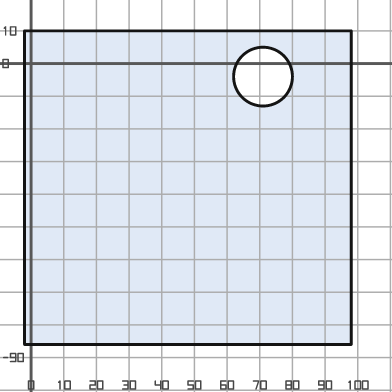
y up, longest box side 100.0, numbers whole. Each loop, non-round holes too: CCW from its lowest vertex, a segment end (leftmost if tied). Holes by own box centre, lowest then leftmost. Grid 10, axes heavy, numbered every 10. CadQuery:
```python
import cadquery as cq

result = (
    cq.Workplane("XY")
    .moveTo(-2.0, -86.0)
    .lineTo(98.0, -86.0)
    .lineTo(98.0, 10.0)
    .lineTo(-2.0, 10.0)
    .close()
    .moveTo(71.0, -4.0)
    .circle(9.0)
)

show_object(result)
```